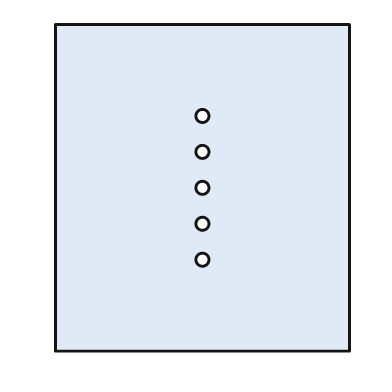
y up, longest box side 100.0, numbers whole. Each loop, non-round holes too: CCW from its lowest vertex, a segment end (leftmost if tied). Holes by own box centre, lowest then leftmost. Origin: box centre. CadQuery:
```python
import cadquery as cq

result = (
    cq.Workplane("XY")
    .moveTo(-45.0, -50.0)
    .lineTo(45.0, -50.0)
    .lineTo(45.0, 50.0)
    .lineTo(-45.0, 50.0)
    .close()
    .moveTo(0.0, -22.0)
    .circle(2.0)
    .moveTo(0.0, -11.0)
    .circle(2.0)
    .moveTo(0.0, 0.0)
    .circle(2.0)
    .moveTo(0.0, 11.0)
    .circle(2.0)
    .moveTo(0.0, 22.0)
    .circle(2.0)
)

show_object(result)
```